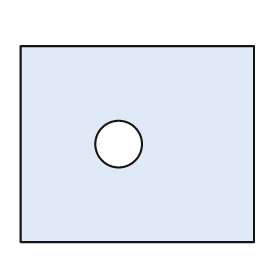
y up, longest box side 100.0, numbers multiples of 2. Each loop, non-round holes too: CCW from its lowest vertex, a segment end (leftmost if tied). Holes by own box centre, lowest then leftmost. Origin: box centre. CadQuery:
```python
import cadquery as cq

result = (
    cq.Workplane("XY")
    .moveTo(-50.0, -42.0)
    .lineTo(50.0, -42.0)
    .lineTo(50.0, 42.0)
    .lineTo(-50.0, 42.0)
    .close()
    .moveTo(-8.0, 0.0)
    .circle(10.0)
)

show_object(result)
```